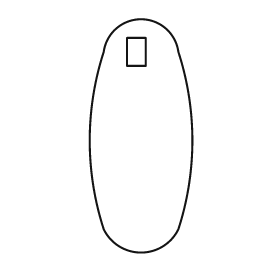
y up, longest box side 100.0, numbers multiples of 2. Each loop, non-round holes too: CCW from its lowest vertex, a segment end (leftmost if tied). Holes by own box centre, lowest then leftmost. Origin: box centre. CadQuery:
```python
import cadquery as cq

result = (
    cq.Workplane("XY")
    .moveTo(-16.0, -40.0)
    .threePointArc((0.0, -50.0), (16.0, -40.0))
    .threePointArc((22.0, -2.0), (16.0, 36.0))
    .threePointArc((0.0, 50.0), (-16.0, 36.0))
    .threePointArc((-22.0, -2.0), (-16.0, -40.0))
    .close()
    .moveTo(-6.0, 30.0)
    .lineTo(2.0, 30.0)
    .lineTo(2.0, 42.0)
    .lineTo(-6.0, 42.0)
    .close()
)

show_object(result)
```